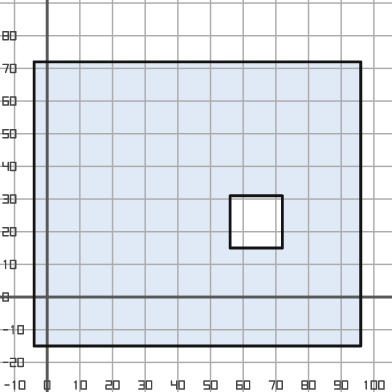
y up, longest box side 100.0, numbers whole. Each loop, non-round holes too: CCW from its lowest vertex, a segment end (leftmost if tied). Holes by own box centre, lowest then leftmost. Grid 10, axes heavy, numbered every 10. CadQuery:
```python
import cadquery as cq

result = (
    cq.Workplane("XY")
    .moveTo(-4.0, -15.0)
    .lineTo(96.0, -15.0)
    .lineTo(96.0, 72.0)
    .lineTo(-4.0, 72.0)
    .close()
    .moveTo(56.0, 15.0)
    .lineTo(72.0, 15.0)
    .lineTo(72.0, 31.0)
    .lineTo(56.0, 31.0)
    .close()
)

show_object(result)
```